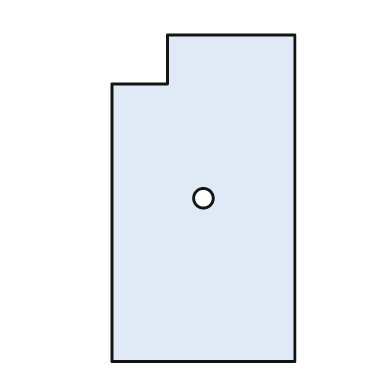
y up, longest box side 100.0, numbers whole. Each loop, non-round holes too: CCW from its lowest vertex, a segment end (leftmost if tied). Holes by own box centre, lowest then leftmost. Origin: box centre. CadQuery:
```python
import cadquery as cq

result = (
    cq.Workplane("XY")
    .moveTo(-28.0, -50.0)
    .lineTo(28.0, -50.0)
    .lineTo(28.0, 50.0)
    .lineTo(-11.0, 50.0)
    .lineTo(-11.0, 35.0)
    .lineTo(-28.0, 35.0)
    .close()
    .moveTo(0.0, 0.0)
    .circle(3.0)
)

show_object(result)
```